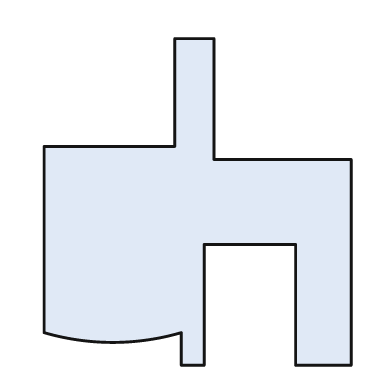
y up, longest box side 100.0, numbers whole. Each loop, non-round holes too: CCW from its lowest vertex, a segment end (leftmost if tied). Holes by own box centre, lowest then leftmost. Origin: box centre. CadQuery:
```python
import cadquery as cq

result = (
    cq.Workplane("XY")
    .moveTo(-5.0, -50.0)
    .lineTo(2.0, -50.0)
    .lineTo(2.0, -13.0)
    .lineTo(30.0, -13.0)
    .lineTo(30.0, -50.0)
    .lineTo(47.0, -50.0)
    .lineTo(47.0, 13.0)
    .lineTo(5.0, 13.0)
    .lineTo(5.0, 50.0)
    .lineTo(-7.0, 50.0)
    .lineTo(-7.0, 17.0)
    .lineTo(-47.0, 17.0)
    .lineTo(-47.0, -40.0)
    .threePointArc((-26.0, -43.0), (-5.0, -40.0))
    .close()
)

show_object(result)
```